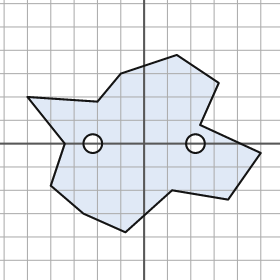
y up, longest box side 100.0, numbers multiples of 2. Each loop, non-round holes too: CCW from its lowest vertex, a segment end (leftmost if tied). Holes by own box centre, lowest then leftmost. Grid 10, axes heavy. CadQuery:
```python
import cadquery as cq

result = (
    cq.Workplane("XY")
    .moveTo(-8.0, -38.0)
    .lineTo(12.0, -20.0)
    .lineTo(36.0, -24.0)
    .lineTo(50.0, -4.0)
    .lineTo(24.0, 8.0)
    .lineTo(32.0, 26.0)
    .lineTo(14.0, 38.0)
    .lineTo(-10.0, 30.0)
    .lineTo(-20.0, 18.0)
    .lineTo(-50.0, 20.0)
    .lineTo(-34.0, 0.0)
    .lineTo(-40.0, -18.0)
    .lineTo(-26.0, -30.0)
    .close()
    .moveTo(-22.0, 0.0)
    .circle(4.0)
    .moveTo(22.0, 0.0)
    .circle(4.0)
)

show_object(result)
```